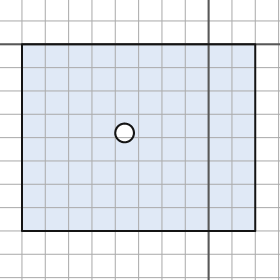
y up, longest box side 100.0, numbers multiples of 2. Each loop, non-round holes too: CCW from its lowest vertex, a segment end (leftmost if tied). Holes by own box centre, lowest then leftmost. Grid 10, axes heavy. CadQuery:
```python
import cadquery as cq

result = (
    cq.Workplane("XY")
    .moveTo(-80.0, -80.0)
    .lineTo(20.0, -80.0)
    .lineTo(20.0, 0.0)
    .lineTo(-80.0, 0.0)
    .close()
    .moveTo(-36.0, -38.0)
    .circle(4.0)
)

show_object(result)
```